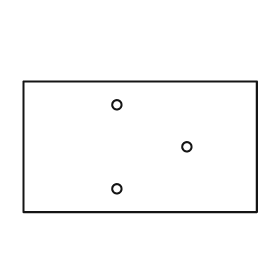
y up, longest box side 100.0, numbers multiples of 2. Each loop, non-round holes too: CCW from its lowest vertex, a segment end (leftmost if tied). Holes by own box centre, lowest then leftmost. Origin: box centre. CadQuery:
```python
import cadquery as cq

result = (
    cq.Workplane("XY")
    .moveTo(-50.0, -28.0)
    .lineTo(50.0, -28.0)
    .lineTo(50.0, 28.0)
    .lineTo(-50.0, 28.0)
    .close()
    .moveTo(-10.0, -18.0)
    .circle(2.0)
    .moveTo(20.0, 0.0)
    .circle(2.0)
    .moveTo(-10.0, 18.0)
    .circle(2.0)
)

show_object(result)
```